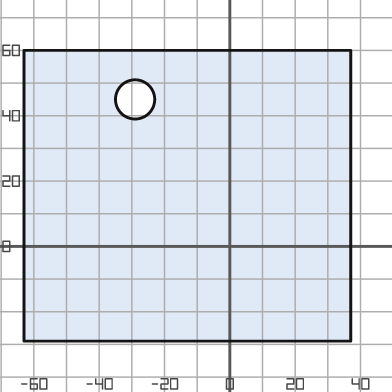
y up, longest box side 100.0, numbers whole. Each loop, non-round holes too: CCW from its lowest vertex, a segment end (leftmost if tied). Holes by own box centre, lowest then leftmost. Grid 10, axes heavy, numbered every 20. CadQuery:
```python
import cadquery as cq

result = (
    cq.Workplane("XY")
    .moveTo(-63.0, -29.0)
    .lineTo(37.0, -29.0)
    .lineTo(37.0, 60.0)
    .lineTo(-63.0, 60.0)
    .close()
    .moveTo(-29.0, 45.0)
    .circle(6.0)
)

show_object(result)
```